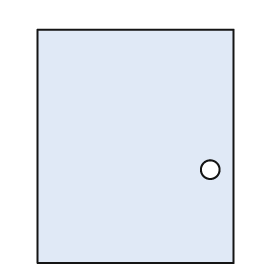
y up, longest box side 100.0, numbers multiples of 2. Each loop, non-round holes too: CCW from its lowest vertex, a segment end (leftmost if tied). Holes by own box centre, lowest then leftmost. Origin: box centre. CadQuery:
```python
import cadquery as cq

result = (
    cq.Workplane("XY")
    .moveTo(-42.0, -50.0)
    .lineTo(42.0, -50.0)
    .lineTo(42.0, 50.0)
    .lineTo(-42.0, 50.0)
    .close()
    .moveTo(32.0, -10.0)
    .circle(4.0)
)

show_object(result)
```